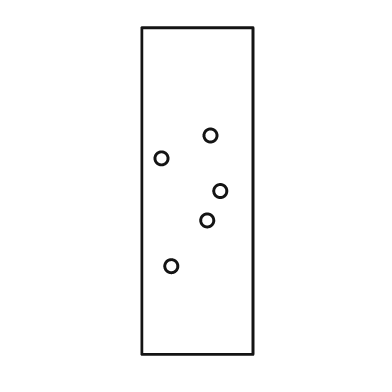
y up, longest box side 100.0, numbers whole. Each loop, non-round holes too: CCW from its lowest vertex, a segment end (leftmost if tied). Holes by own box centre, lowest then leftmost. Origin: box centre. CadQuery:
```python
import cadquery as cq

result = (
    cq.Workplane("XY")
    .moveTo(-17.0, -50.0)
    .lineTo(17.0, -50.0)
    .lineTo(17.0, 50.0)
    .lineTo(-17.0, 50.0)
    .close()
    .moveTo(-8.0, -23.0)
    .circle(2.0)
    .moveTo(3.0, -9.0)
    .circle(2.0)
    .moveTo(7.0, 0.0)
    .circle(2.0)
    .moveTo(-11.0, 10.0)
    .circle(2.0)
    .moveTo(4.0, 17.0)
    .circle(2.0)
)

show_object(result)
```